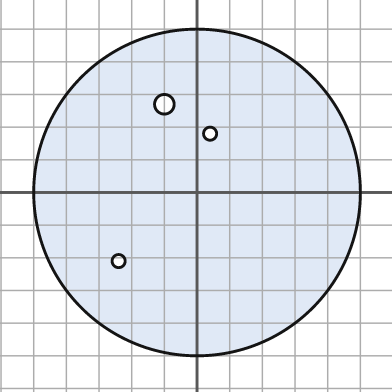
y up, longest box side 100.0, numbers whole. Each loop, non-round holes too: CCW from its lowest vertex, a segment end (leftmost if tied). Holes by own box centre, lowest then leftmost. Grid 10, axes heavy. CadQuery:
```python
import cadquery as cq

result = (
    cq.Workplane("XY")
    .moveTo(0.0, 0.0)
    .circle(50.0)
    .moveTo(-24.0, -21.0)
    .circle(2.0)
    .moveTo(4.0, 18.0)
    .circle(2.0)
    .moveTo(-10.0, 27.0)
    .circle(3.0)
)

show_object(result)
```